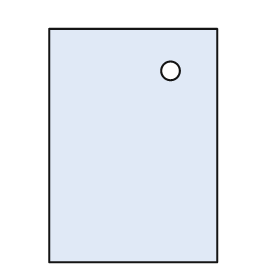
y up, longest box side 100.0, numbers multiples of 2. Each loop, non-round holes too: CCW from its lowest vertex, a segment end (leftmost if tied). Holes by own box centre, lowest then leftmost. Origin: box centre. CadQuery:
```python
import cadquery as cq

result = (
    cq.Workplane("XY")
    .moveTo(-36.0, -50.0)
    .lineTo(36.0, -50.0)
    .lineTo(36.0, 50.0)
    .lineTo(-36.0, 50.0)
    .close()
    .moveTo(16.0, 32.0)
    .circle(4.0)
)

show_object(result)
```